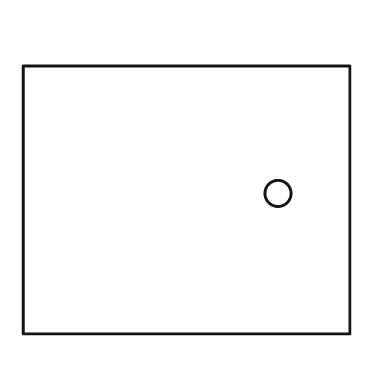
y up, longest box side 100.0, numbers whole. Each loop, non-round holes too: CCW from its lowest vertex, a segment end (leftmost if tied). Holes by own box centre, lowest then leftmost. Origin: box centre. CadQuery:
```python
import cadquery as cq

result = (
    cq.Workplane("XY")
    .moveTo(-50.0, -41.0)
    .lineTo(50.0, -41.0)
    .lineTo(50.0, 41.0)
    .lineTo(-50.0, 41.0)
    .close()
    .moveTo(28.0, 2.0)
    .circle(4.0)
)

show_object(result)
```